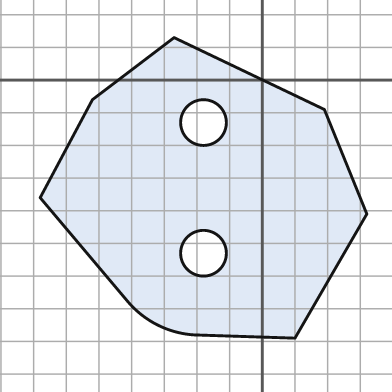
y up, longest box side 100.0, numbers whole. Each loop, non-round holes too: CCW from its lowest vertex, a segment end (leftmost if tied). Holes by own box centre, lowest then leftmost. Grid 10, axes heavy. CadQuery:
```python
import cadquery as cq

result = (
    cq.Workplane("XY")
    .moveTo(10.0, -79.0)
    .lineTo(32.0, -41.0)
    .lineTo(19.0, -9.0)
    .lineTo(-27.0, 13.0)
    .lineTo(-52.0, -6.0)
    .lineTo(-68.0, -36.0)
    .lineTo(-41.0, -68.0)
    .threePointArc((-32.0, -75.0), (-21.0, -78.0))
    .close()
    .moveTo(-18.0, -53.0)
    .circle(7.0)
    .moveTo(-18.0, -13.0)
    .circle(7.0)
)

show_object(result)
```